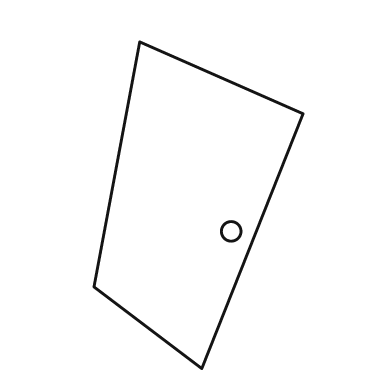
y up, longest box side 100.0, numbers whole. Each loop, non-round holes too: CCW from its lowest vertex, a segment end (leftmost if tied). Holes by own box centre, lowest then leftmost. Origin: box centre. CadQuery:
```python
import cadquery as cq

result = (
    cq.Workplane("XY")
    .moveTo(1.0, -50.0)
    .lineTo(32.0, 28.0)
    .lineTo(-18.0, 50.0)
    .lineTo(-32.0, -25.0)
    .close()
    .moveTo(10.0, -8.0)
    .circle(3.0)
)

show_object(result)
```